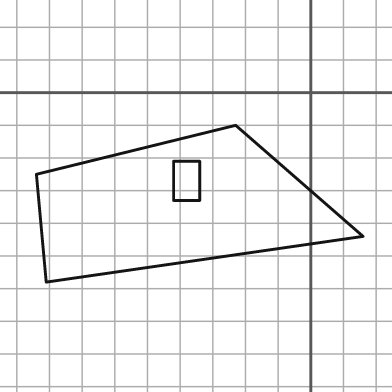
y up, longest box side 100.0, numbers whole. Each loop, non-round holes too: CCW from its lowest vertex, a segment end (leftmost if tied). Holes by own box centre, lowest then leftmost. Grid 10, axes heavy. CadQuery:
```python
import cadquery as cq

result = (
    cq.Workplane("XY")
    .moveTo(-81.0, -58.0)
    .lineTo(16.0, -44.0)
    .lineTo(-23.0, -10.0)
    .lineTo(-84.0, -25.0)
    .close()
    .moveTo(-42.0, -33.0)
    .lineTo(-34.0, -33.0)
    .lineTo(-34.0, -21.0)
    .lineTo(-42.0, -21.0)
    .close()
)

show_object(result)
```